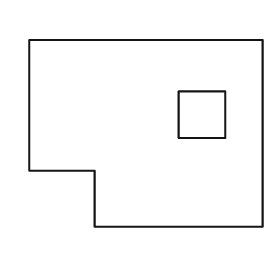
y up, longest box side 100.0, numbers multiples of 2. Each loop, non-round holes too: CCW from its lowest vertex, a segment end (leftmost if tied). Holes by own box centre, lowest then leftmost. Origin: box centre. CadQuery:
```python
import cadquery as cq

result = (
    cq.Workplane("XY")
    .moveTo(-22.0, -40.0)
    .lineTo(50.0, -40.0)
    .lineTo(50.0, 40.0)
    .lineTo(-50.0, 40.0)
    .lineTo(-50.0, -16.0)
    .lineTo(-22.0, -16.0)
    .close()
    .moveTo(14.0, -2.0)
    .lineTo(34.0, -2.0)
    .lineTo(34.0, 18.0)
    .lineTo(14.0, 18.0)
    .close()
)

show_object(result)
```